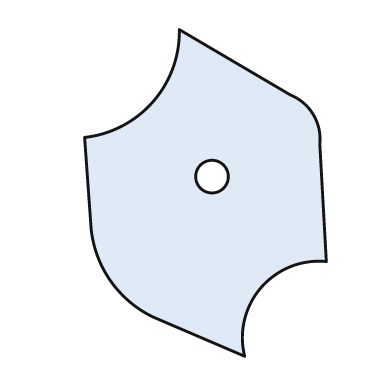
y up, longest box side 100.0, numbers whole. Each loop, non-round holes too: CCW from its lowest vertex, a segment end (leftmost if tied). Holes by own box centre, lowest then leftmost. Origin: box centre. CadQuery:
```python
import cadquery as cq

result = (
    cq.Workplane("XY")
    .moveTo(12.0, -50.0)
    .threePointArc((17.0, -29.0), (37.0, -21.0))
    .lineTo(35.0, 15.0)
    .threePointArc((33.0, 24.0), (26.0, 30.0))
    .lineTo(-8.0, 50.0)
    .threePointArc((-16.0, 28.0), (-37.0, 17.0))
    .lineTo(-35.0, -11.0)
    .threePointArc((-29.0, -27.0), (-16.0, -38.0))
    .close()
    .moveTo(2.0, 5.0)
    .circle(5.0)
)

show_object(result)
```